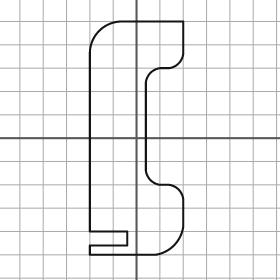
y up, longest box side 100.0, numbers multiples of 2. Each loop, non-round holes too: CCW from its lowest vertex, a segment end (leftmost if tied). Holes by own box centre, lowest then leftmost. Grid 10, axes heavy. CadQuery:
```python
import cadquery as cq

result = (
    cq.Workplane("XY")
    .moveTo(-20.0, -50.0)
    .lineTo(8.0, -50.0)
    .threePointArc((16.0, -46.0), (20.0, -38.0))
    .lineTo(20.0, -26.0)
    .threePointArc((18.0, -22.0), (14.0, -20.0))
    .lineTo(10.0, -20.0)
    .threePointArc((6.0, -18.0), (4.0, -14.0))
    .lineTo(4.0, 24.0)
    .threePointArc((6.0, 28.0), (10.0, 30.0))
    .lineTo(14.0, 30.0)
    .threePointArc((18.0, 32.0), (20.0, 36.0))
    .lineTo(20.0, 50.0)
    .lineTo(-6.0, 50.0)
    .threePointArc((-16.0, 46.0), (-20.0, 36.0))
    .lineTo(-20.0, -40.0)
    .lineTo(-4.0, -40.0)
    .lineTo(-4.0, -46.0)
    .lineTo(-20.0, -46.0)
    .close()
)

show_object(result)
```